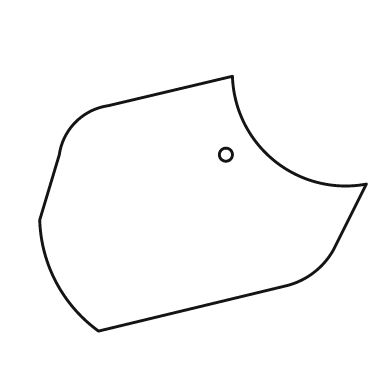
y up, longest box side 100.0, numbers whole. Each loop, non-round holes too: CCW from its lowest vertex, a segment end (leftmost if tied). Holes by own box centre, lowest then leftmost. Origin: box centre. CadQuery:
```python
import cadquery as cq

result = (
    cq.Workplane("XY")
    .moveTo(-32.0, -39.0)
    .lineTo(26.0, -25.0)
    .threePointArc((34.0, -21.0), (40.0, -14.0))
    .lineTo(50.0, 6.0)
    .threePointArc((22.0, 13.0), (9.0, 39.0))
    .lineTo(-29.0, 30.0)
    .threePointArc((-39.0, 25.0), (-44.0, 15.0))
    .lineTo(-50.0, -5.0)
    .threePointArc((-45.0, -24.0), (-32.0, -39.0))
    .close()
    .moveTo(7.0, 15.0)
    .circle(2.0)
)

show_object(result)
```